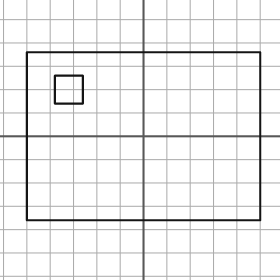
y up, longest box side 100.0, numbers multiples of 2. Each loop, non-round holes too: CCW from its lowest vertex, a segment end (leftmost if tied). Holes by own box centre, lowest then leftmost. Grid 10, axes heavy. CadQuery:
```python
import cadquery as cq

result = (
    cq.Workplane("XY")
    .moveTo(-50.0, -36.0)
    .lineTo(50.0, -36.0)
    .lineTo(50.0, 36.0)
    .lineTo(-50.0, 36.0)
    .close()
    .moveTo(-38.0, 14.0)
    .lineTo(-26.0, 14.0)
    .lineTo(-26.0, 26.0)
    .lineTo(-38.0, 26.0)
    .close()
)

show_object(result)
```